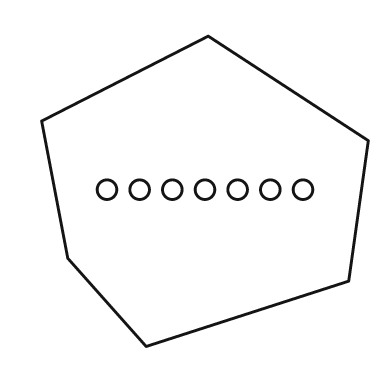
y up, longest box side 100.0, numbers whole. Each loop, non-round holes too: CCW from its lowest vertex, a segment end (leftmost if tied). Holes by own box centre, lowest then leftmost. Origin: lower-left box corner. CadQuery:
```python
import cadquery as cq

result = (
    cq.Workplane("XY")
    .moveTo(32.0, 0.0)
    .lineTo(94.0, 20.0)
    .lineTo(100.0, 63.0)
    .lineTo(51.0, 95.0)
    .lineTo(0.0, 69.0)
    .lineTo(8.0, 27.0)
    .close()
    .moveTo(20.0, 48.0)
    .circle(3.0)
    .moveTo(30.0, 48.0)
    .circle(3.0)
    .moveTo(40.0, 48.0)
    .circle(3.0)
    .moveTo(50.0, 48.0)
    .circle(3.0)
    .moveTo(60.0, 48.0)
    .circle(3.0)
    .moveTo(70.0, 48.0)
    .circle(3.0)
    .moveTo(80.0, 48.0)
    .circle(3.0)
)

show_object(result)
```